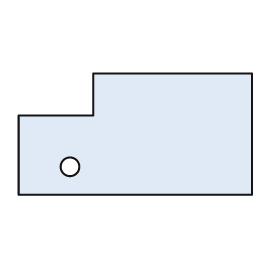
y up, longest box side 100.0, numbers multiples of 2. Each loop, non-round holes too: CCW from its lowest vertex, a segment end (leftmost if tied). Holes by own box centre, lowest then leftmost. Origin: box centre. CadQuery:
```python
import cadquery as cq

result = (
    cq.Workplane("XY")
    .moveTo(-50.0, -26.0)
    .lineTo(50.0, -26.0)
    .lineTo(50.0, 26.0)
    .lineTo(-18.0, 26.0)
    .lineTo(-18.0, 8.0)
    .lineTo(-50.0, 8.0)
    .close()
    .moveTo(-28.0, -14.0)
    .circle(4.0)
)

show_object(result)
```